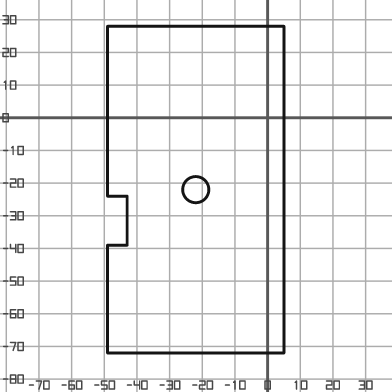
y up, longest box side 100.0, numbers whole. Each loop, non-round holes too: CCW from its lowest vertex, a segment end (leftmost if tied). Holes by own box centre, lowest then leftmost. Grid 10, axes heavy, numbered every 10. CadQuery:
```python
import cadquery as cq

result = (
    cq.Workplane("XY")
    .moveTo(-49.0, -72.0)
    .lineTo(5.0, -72.0)
    .lineTo(5.0, 28.0)
    .lineTo(-49.0, 28.0)
    .lineTo(-49.0, -24.0)
    .lineTo(-43.0, -24.0)
    .lineTo(-43.0, -39.0)
    .lineTo(-49.0, -39.0)
    .close()
    .moveTo(-22.0, -22.0)
    .circle(4.0)
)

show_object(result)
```